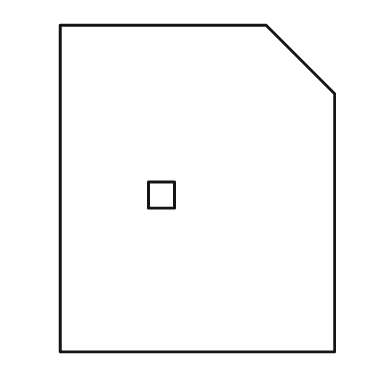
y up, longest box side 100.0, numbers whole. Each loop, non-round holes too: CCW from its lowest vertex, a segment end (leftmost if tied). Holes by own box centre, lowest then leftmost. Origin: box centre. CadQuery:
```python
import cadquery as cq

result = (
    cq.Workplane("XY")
    .moveTo(-42.0, -50.0)
    .lineTo(42.0, -50.0)
    .lineTo(42.0, 29.0)
    .lineTo(21.0, 50.0)
    .lineTo(-42.0, 50.0)
    .close()
    .moveTo(-15.0, -6.0)
    .lineTo(-7.0, -6.0)
    .lineTo(-7.0, 2.0)
    .lineTo(-15.0, 2.0)
    .close()
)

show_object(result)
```